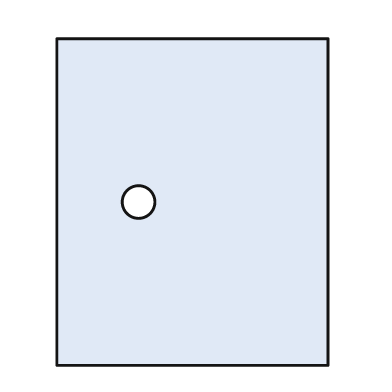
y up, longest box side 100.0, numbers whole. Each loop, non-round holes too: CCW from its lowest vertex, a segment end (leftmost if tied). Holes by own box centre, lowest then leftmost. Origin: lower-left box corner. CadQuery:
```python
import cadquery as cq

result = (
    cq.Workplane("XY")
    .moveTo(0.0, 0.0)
    .lineTo(83.0, 0.0)
    .lineTo(83.0, 100.0)
    .lineTo(0.0, 100.0)
    .close()
    .moveTo(25.0, 50.0)
    .circle(5.0)
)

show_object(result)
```